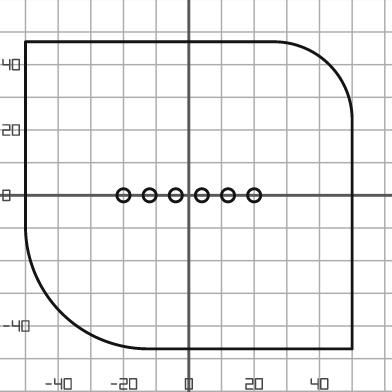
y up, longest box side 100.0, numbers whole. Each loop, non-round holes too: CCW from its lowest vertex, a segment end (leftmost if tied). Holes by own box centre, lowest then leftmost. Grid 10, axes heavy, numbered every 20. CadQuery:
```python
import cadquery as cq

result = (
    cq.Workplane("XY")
    .moveTo(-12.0, -47.0)
    .lineTo(50.0, -47.0)
    .lineTo(50.0, 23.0)
    .threePointArc((43.0, 40.0), (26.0, 47.0))
    .lineTo(-50.0, 47.0)
    .lineTo(-50.0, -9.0)
    .threePointArc((-39.0, -36.0), (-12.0, -47.0))
    .close()
    .moveTo(-20.0, 0.0)
    .circle(2.0)
    .moveTo(-12.0, 0.0)
    .circle(2.0)
    .moveTo(-4.0, 0.0)
    .circle(2.0)
    .moveTo(4.0, 0.0)
    .circle(2.0)
    .moveTo(12.0, 0.0)
    .circle(2.0)
    .moveTo(20.0, 0.0)
    .circle(2.0)
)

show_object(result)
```